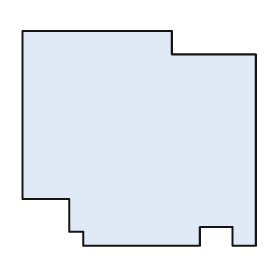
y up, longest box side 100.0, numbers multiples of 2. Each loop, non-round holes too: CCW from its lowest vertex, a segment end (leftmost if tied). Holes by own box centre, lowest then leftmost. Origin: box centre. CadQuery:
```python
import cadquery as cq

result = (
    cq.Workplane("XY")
    .moveTo(-24.0, -46.0)
    .lineTo(26.0, -46.0)
    .lineTo(26.0, -38.0)
    .lineTo(40.0, -38.0)
    .lineTo(40.0, -46.0)
    .lineTo(50.0, -46.0)
    .lineTo(50.0, 36.0)
    .lineTo(14.0, 36.0)
    .lineTo(14.0, 46.0)
    .lineTo(-50.0, 46.0)
    .lineTo(-50.0, -26.0)
    .lineTo(-30.0, -26.0)
    .lineTo(-30.0, -40.0)
    .lineTo(-24.0, -40.0)
    .close()
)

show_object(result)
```